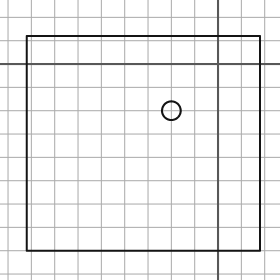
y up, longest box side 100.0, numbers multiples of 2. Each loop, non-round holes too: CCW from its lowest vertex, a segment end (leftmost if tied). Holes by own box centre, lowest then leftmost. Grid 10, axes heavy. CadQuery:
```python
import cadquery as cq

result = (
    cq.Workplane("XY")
    .moveTo(-82.0, -80.0)
    .lineTo(18.0, -80.0)
    .lineTo(18.0, 12.0)
    .lineTo(-82.0, 12.0)
    .close()
    .moveTo(-20.0, -20.0)
    .circle(4.0)
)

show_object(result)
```